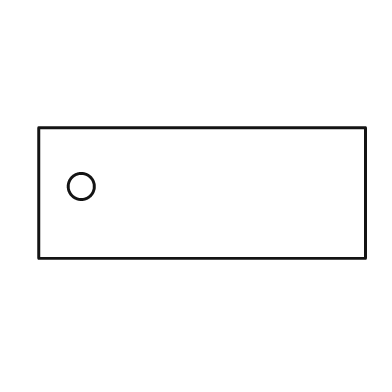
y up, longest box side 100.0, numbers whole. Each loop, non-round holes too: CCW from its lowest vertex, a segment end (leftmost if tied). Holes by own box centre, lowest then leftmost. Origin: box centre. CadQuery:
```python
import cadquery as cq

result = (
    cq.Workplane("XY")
    .moveTo(-50.0, -20.0)
    .lineTo(50.0, -20.0)
    .lineTo(50.0, 20.0)
    .lineTo(-50.0, 20.0)
    .close()
    .moveTo(-37.0, 2.0)
    .circle(4.0)
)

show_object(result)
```